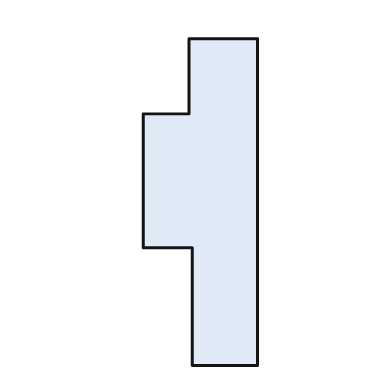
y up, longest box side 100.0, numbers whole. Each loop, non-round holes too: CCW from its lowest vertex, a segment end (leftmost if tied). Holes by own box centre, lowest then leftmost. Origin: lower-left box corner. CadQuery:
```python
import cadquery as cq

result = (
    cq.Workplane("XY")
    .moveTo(15.0, 0.0)
    .lineTo(35.0, 0.0)
    .lineTo(35.0, 100.0)
    .lineTo(14.0, 100.0)
    .lineTo(14.0, 77.0)
    .lineTo(0.0, 77.0)
    .lineTo(0.0, 36.0)
    .lineTo(15.0, 36.0)
    .close()
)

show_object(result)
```